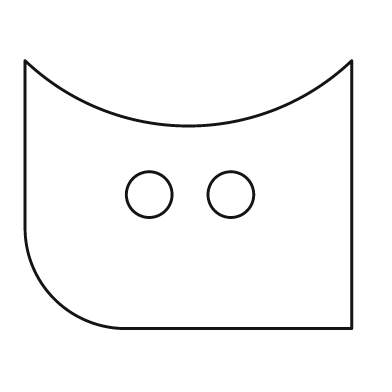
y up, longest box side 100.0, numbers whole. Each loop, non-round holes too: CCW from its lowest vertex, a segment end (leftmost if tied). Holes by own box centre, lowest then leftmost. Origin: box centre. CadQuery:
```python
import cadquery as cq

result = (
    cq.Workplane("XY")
    .moveTo(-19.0, -41.0)
    .lineTo(50.0, -41.0)
    .lineTo(50.0, 41.0)
    .threePointArc((0.0, 21.0), (-50.0, 41.0))
    .lineTo(-50.0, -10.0)
    .threePointArc((-41.0, -32.0), (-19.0, -41.0))
    .close()
    .moveTo(-12.0, 0.0)
    .circle(7.0)
    .moveTo(13.0, 0.0)
    .circle(7.0)
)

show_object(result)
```